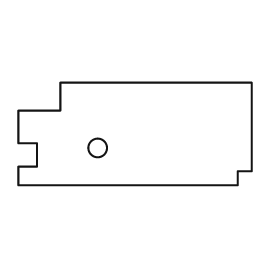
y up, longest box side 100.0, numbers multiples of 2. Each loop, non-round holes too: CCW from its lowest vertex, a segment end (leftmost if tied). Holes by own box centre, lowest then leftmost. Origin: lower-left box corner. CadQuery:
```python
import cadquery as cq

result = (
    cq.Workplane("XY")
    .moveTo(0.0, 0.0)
    .lineTo(94.0, 0.0)
    .lineTo(94.0, 6.0)
    .lineTo(100.0, 6.0)
    .lineTo(100.0, 44.0)
    .lineTo(18.0, 44.0)
    .lineTo(18.0, 32.0)
    .lineTo(0.0, 32.0)
    .lineTo(0.0, 18.0)
    .lineTo(8.0, 18.0)
    .lineTo(8.0, 8.0)
    .lineTo(0.0, 8.0)
    .close()
    .moveTo(34.0, 16.0)
    .circle(4.0)
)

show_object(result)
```